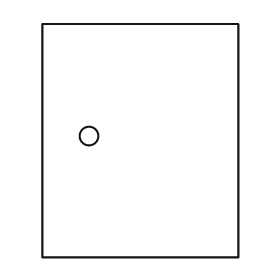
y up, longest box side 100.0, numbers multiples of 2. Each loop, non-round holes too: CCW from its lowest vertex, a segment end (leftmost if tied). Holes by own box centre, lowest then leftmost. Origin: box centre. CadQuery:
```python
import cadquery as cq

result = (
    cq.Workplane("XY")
    .moveTo(-42.0, -50.0)
    .lineTo(42.0, -50.0)
    .lineTo(42.0, 50.0)
    .lineTo(-42.0, 50.0)
    .close()
    .moveTo(-22.0, 2.0)
    .circle(4.0)
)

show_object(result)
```